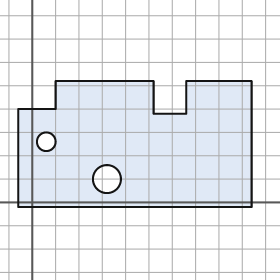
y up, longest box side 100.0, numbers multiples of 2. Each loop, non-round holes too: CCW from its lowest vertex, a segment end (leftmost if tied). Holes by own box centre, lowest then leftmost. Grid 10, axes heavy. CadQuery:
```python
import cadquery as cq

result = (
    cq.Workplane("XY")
    .moveTo(-6.0, -2.0)
    .lineTo(94.0, -2.0)
    .lineTo(94.0, 52.0)
    .lineTo(66.0, 52.0)
    .lineTo(66.0, 38.0)
    .lineTo(52.0, 38.0)
    .lineTo(52.0, 52.0)
    .lineTo(10.0, 52.0)
    .lineTo(10.0, 40.0)
    .lineTo(-6.0, 40.0)
    .close()
    .moveTo(32.0, 10.0)
    .circle(6.0)
    .moveTo(6.0, 26.0)
    .circle(4.0)
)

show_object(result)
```